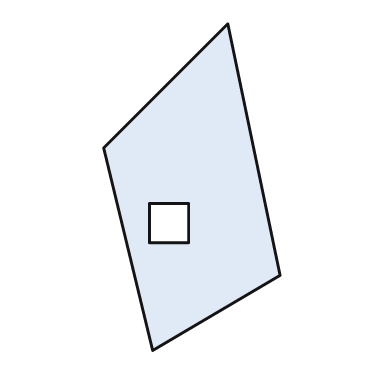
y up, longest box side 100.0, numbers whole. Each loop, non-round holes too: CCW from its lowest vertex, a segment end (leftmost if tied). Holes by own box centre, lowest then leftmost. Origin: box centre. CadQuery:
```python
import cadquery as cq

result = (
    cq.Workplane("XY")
    .moveTo(-12.0, -50.0)
    .lineTo(27.0, -27.0)
    .lineTo(11.0, 50.0)
    .lineTo(-27.0, 12.0)
    .close()
    .moveTo(-13.0, -17.0)
    .lineTo(-1.0, -17.0)
    .lineTo(-1.0, -5.0)
    .lineTo(-13.0, -5.0)
    .close()
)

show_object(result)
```